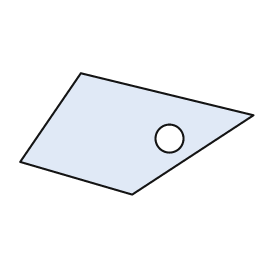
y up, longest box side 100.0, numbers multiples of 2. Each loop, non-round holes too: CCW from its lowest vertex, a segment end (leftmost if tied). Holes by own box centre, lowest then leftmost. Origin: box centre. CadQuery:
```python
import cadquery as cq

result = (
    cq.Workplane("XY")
    .moveTo(-2.0, -26.0)
    .lineTo(50.0, 8.0)
    .lineTo(-24.0, 26.0)
    .lineTo(-50.0, -12.0)
    .close()
    .moveTo(14.0, -2.0)
    .circle(6.0)
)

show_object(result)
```